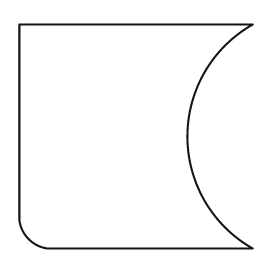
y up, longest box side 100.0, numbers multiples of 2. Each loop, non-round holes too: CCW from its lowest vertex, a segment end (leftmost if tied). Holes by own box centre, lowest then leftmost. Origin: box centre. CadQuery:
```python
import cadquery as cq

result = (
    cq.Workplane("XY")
    .moveTo(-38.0, -48.0)
    .lineTo(50.0, -48.0)
    .threePointArc((22.0, 0.0), (50.0, 48.0))
    .lineTo(-50.0, 48.0)
    .lineTo(-50.0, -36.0)
    .threePointArc((-46.0, -44.0), (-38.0, -48.0))
    .close()
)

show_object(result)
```